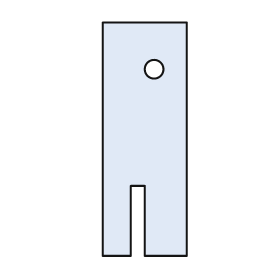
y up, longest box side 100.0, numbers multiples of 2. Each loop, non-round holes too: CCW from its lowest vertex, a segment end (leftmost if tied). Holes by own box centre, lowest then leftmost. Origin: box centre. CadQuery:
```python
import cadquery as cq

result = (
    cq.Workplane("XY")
    .moveTo(-18.0, -50.0)
    .lineTo(-6.0, -50.0)
    .lineTo(-6.0, -20.0)
    .lineTo(0.0, -20.0)
    .lineTo(0.0, -50.0)
    .lineTo(18.0, -50.0)
    .lineTo(18.0, 50.0)
    .lineTo(-18.0, 50.0)
    .close()
    .moveTo(4.0, 30.0)
    .circle(4.0)
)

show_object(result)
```